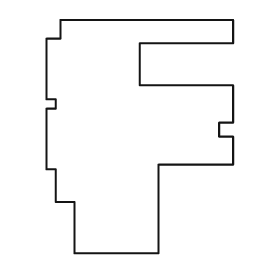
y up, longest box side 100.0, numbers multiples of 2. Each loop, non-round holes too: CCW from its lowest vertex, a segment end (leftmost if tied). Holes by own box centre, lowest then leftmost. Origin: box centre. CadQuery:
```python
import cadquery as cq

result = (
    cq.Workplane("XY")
    .moveTo(-28.0, -50.0)
    .lineTo(8.0, -50.0)
    .lineTo(8.0, -12.0)
    .lineTo(40.0, -12.0)
    .lineTo(40.0, 0.0)
    .lineTo(34.0, 0.0)
    .lineTo(34.0, 6.0)
    .lineTo(40.0, 6.0)
    .lineTo(40.0, 22.0)
    .lineTo(0.0, 22.0)
    .lineTo(0.0, 40.0)
    .lineTo(40.0, 40.0)
    .lineTo(40.0, 50.0)
    .lineTo(-34.0, 50.0)
    .lineTo(-34.0, 42.0)
    .lineTo(-40.0, 42.0)
    .lineTo(-40.0, 16.0)
    .lineTo(-36.0, 16.0)
    .lineTo(-36.0, 12.0)
    .lineTo(-40.0, 12.0)
    .lineTo(-40.0, -14.0)
    .lineTo(-36.0, -14.0)
    .lineTo(-36.0, -28.0)
    .lineTo(-28.0, -28.0)
    .close()
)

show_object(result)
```